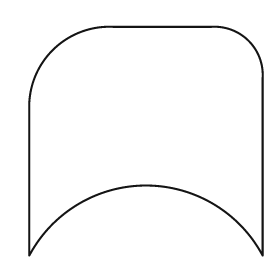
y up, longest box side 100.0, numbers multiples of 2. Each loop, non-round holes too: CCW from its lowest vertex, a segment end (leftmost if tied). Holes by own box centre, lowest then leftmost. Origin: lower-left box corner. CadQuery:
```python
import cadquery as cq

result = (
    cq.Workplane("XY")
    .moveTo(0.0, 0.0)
    .threePointArc((50.0, 30.0), (100.0, 0.0))
    .lineTo(100.0, 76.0)
    .threePointArc((94.0, 92.0), (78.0, 98.0))
    .lineTo(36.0, 98.0)
    .threePointArc((10.0, 88.0), (0.0, 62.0))
    .close()
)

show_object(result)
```